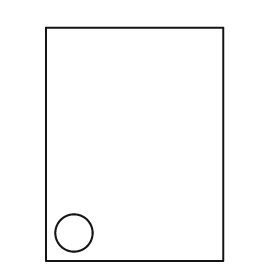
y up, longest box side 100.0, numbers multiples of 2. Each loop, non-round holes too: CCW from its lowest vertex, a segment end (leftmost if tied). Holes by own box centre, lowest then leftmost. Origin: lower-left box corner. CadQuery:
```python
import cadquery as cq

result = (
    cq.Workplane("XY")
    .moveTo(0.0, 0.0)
    .lineTo(76.0, 0.0)
    .lineTo(76.0, 100.0)
    .lineTo(0.0, 100.0)
    .close()
    .moveTo(12.0, 12.0)
    .circle(8.0)
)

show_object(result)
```